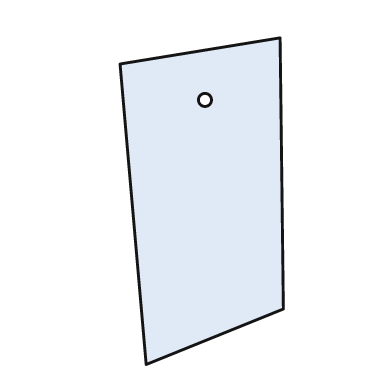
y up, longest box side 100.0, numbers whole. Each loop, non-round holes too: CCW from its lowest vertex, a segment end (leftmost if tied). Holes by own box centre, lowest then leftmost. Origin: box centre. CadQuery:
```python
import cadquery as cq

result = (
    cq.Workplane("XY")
    .moveTo(-17.0, -50.0)
    .lineTo(25.0, -33.0)
    .lineTo(24.0, 50.0)
    .lineTo(-25.0, 42.0)
    .close()
    .moveTo(1.0, 31.0)
    .circle(2.0)
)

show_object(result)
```